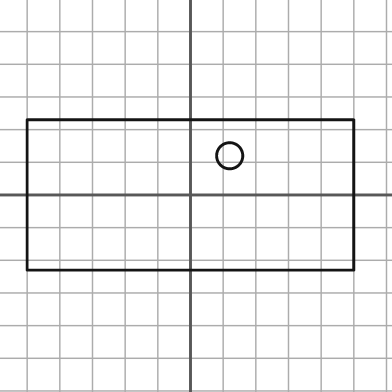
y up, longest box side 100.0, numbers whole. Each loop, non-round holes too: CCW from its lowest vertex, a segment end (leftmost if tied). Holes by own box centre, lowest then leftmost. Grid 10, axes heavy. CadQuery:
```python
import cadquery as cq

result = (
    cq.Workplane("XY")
    .moveTo(-50.0, -23.0)
    .lineTo(50.0, -23.0)
    .lineTo(50.0, 23.0)
    .lineTo(-50.0, 23.0)
    .close()
    .moveTo(12.0, 12.0)
    .circle(4.0)
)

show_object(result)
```